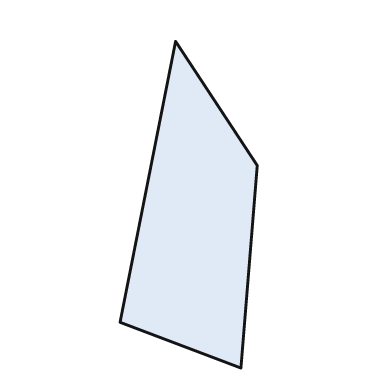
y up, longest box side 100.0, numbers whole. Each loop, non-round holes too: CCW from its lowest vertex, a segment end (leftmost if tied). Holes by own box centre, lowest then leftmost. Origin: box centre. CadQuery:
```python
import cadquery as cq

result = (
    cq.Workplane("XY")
    .moveTo(16.0, -50.0)
    .lineTo(21.0, 12.0)
    .lineTo(-4.0, 50.0)
    .lineTo(-21.0, -36.0)
    .close()
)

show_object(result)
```